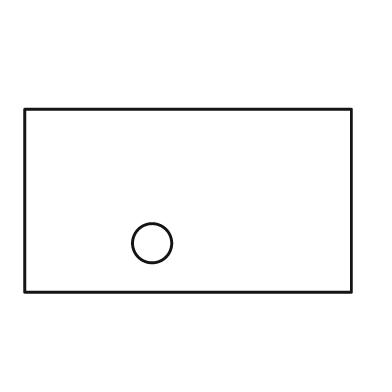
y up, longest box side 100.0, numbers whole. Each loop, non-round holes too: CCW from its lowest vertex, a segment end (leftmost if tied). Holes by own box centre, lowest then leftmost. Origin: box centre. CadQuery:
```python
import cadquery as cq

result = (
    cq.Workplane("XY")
    .moveTo(-50.0, -28.0)
    .lineTo(50.0, -28.0)
    .lineTo(50.0, 28.0)
    .lineTo(-50.0, 28.0)
    .close()
    .moveTo(-11.0, -13.0)
    .circle(6.0)
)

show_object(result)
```